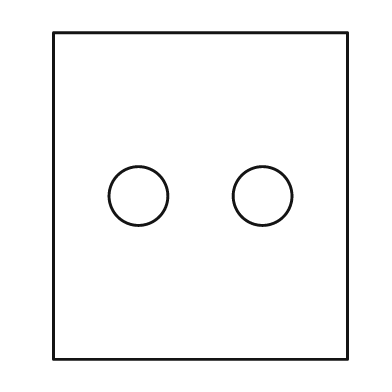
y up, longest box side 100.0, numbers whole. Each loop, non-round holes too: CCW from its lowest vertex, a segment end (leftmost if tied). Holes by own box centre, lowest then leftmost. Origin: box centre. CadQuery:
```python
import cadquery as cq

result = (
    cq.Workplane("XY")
    .moveTo(-45.0, -50.0)
    .lineTo(45.0, -50.0)
    .lineTo(45.0, 50.0)
    .lineTo(-45.0, 50.0)
    .close()
    .moveTo(-19.0, 0.0)
    .circle(9.0)
    .moveTo(19.0, 0.0)
    .circle(9.0)
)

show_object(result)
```